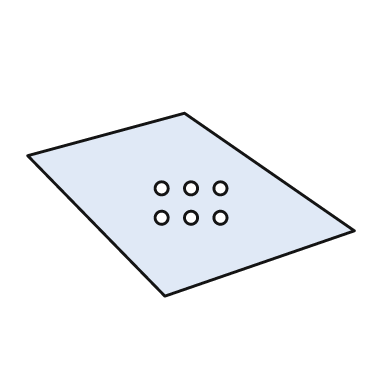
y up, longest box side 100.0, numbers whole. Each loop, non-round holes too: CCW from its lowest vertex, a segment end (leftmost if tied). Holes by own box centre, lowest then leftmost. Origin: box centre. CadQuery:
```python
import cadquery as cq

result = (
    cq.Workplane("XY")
    .moveTo(-8.0, -28.0)
    .lineTo(50.0, -8.0)
    .lineTo(-2.0, 28.0)
    .lineTo(-50.0, 15.0)
    .close()
    .moveTo(-9.0, -4.0)
    .circle(2.0)
    .moveTo(0.0, -4.0)
    .circle(2.0)
    .moveTo(9.0, -4.0)
    .circle(2.0)
    .moveTo(-9.0, 5.0)
    .circle(2.0)
    .moveTo(0.0, 5.0)
    .circle(2.0)
    .moveTo(9.0, 5.0)
    .circle(2.0)
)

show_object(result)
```